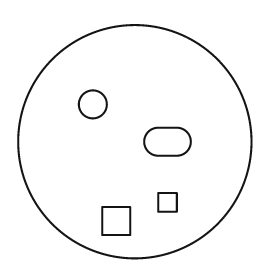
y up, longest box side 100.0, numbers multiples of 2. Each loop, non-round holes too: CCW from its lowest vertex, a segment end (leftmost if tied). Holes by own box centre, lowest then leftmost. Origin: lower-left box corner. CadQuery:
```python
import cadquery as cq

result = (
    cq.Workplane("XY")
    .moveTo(50.0, 50.0)
    .circle(50.0)
    .moveTo(36.0, 10.0)
    .lineTo(48.0, 10.0)
    .lineTo(48.0, 22.0)
    .lineTo(36.0, 22.0)
    .close()
    .moveTo(60.0, 20.0)
    .lineTo(68.0, 20.0)
    .lineTo(68.0, 28.0)
    .lineTo(60.0, 28.0)
    .close()
    .moveTo(60.0, 44.0)
    .lineTo(68.0, 44.0)
    .threePointArc((74.0, 50.0), (68.0, 56.0))
    .lineTo(60.0, 56.0)
    .threePointArc((54.0, 50.0), (60.0, 44.0))
    .close()
    .moveTo(32.0, 66.0)
    .circle(6.0)
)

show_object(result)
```